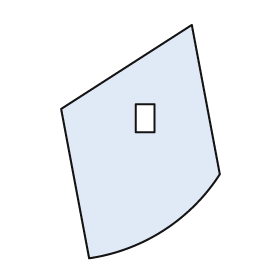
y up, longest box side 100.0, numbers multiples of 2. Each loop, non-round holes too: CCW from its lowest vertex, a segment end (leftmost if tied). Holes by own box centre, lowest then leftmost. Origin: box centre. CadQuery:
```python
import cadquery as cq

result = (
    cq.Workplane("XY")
    .moveTo(-22.0, -50.0)
    .threePointArc((10.0, -38.0), (34.0, -14.0))
    .lineTo(22.0, 50.0)
    .lineTo(-34.0, 14.0)
    .close()
    .moveTo(-2.0, 4.0)
    .lineTo(6.0, 4.0)
    .lineTo(6.0, 16.0)
    .lineTo(-2.0, 16.0)
    .close()
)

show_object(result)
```